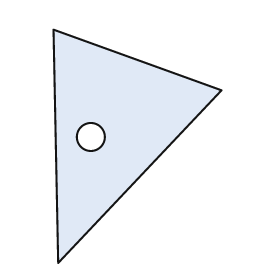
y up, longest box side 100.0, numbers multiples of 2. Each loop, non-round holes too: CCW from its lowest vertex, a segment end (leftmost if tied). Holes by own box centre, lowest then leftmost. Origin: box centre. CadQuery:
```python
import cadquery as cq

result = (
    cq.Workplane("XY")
    .moveTo(-34.0, -50.0)
    .lineTo(36.0, 24.0)
    .lineTo(-36.0, 50.0)
    .close()
    .moveTo(-20.0, 4.0)
    .circle(6.0)
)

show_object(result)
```